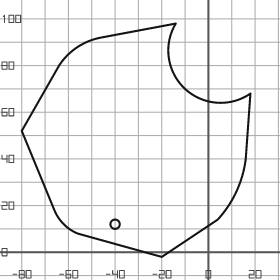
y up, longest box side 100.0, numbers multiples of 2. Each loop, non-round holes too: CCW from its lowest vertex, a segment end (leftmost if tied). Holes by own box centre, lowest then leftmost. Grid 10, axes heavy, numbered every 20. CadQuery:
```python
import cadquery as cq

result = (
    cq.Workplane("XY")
    .moveTo(-20.0, -2.0)
    .lineTo(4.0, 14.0)
    .threePointArc((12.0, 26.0), (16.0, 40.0))
    .lineTo(18.0, 68.0)
    .threePointArc((-10.0, 70.0), (-14.0, 98.0))
    .lineTo(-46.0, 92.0)
    .threePointArc((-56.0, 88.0), (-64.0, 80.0))
    .lineTo(-80.0, 52.0)
    .lineTo(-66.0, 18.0)
    .threePointArc((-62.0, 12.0), (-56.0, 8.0))
    .close()
    .moveTo(-40.0, 12.0)
    .circle(2.0)
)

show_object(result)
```